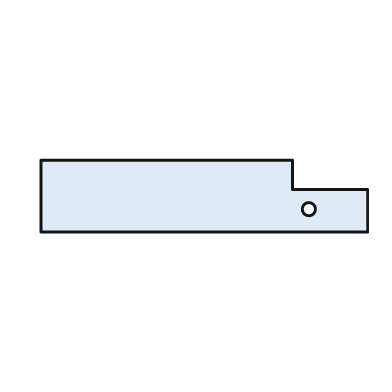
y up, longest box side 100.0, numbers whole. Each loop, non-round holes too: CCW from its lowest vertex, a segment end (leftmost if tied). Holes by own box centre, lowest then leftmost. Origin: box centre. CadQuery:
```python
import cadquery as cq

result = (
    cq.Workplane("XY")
    .moveTo(-50.0, -11.0)
    .lineTo(50.0, -11.0)
    .lineTo(50.0, 2.0)
    .lineTo(27.0, 2.0)
    .lineTo(27.0, 11.0)
    .lineTo(-50.0, 11.0)
    .close()
    .moveTo(32.0, -4.0)
    .circle(2.0)
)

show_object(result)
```